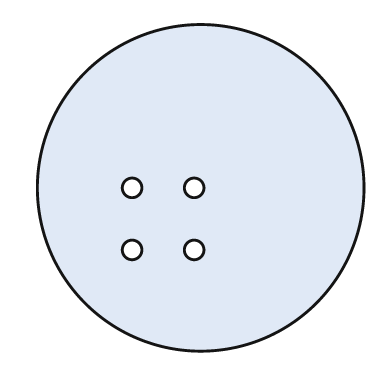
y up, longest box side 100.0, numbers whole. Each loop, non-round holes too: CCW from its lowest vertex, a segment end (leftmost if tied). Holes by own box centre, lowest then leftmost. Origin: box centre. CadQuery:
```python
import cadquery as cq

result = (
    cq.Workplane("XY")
    .moveTo(0.0, 0.0)
    .circle(50.0)
    .moveTo(-21.0, -19.0)
    .circle(3.0)
    .moveTo(-2.0, -19.0)
    .circle(3.0)
    .moveTo(-21.0, 0.0)
    .circle(3.0)
    .moveTo(-2.0, 0.0)
    .circle(3.0)
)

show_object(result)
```